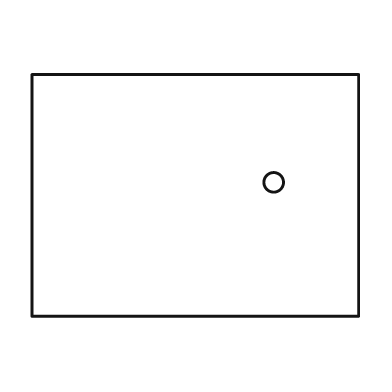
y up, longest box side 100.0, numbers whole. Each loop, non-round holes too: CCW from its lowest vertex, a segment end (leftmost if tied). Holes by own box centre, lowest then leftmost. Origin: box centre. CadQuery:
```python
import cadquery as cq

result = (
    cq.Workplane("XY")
    .moveTo(-50.0, -37.0)
    .lineTo(50.0, -37.0)
    .lineTo(50.0, 37.0)
    .lineTo(-50.0, 37.0)
    .close()
    .moveTo(24.0, 4.0)
    .circle(3.0)
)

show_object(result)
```